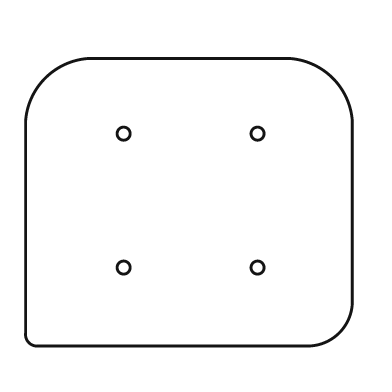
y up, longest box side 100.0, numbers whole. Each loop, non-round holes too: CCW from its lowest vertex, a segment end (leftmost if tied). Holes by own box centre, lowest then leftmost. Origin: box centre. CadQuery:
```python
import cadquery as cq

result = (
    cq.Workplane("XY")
    .moveTo(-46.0, -44.0)
    .lineTo(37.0, -44.0)
    .threePointArc((46.0, -40.0), (50.0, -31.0))
    .lineTo(50.0, 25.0)
    .threePointArc((44.0, 38.0), (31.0, 44.0))
    .lineTo(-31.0, 44.0)
    .threePointArc((-44.0, 38.0), (-50.0, 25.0))
    .lineTo(-50.0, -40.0)
    .threePointArc((-49.0, -43.0), (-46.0, -44.0))
    .close()
    .moveTo(-20.0, -20.0)
    .circle(2.0)
    .moveTo(21.0, -20.0)
    .circle(2.0)
    .moveTo(-20.0, 21.0)
    .circle(2.0)
    .moveTo(21.0, 21.0)
    .circle(2.0)
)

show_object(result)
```